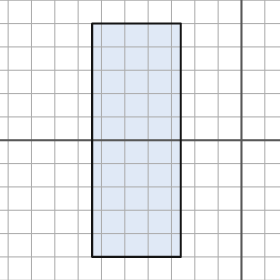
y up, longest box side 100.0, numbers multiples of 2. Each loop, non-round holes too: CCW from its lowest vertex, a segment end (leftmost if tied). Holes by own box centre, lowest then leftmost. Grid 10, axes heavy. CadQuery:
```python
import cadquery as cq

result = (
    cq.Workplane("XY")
    .moveTo(-64.0, -50.0)
    .lineTo(-26.0, -50.0)
    .lineTo(-26.0, 50.0)
    .lineTo(-64.0, 50.0)
    .close()
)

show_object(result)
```